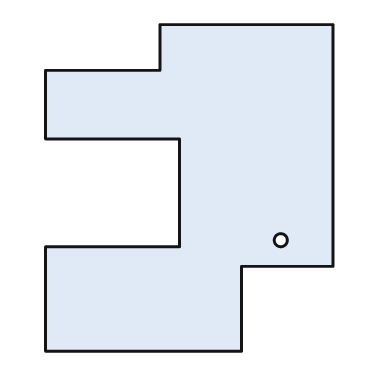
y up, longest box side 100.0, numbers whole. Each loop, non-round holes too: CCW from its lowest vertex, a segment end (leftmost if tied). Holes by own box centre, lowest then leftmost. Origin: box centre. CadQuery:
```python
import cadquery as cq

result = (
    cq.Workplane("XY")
    .moveTo(-44.0, -50.0)
    .lineTo(16.0, -50.0)
    .lineTo(16.0, -24.0)
    .lineTo(44.0, -24.0)
    .lineTo(44.0, 50.0)
    .lineTo(-9.0, 50.0)
    .lineTo(-9.0, 36.0)
    .lineTo(-44.0, 36.0)
    .lineTo(-44.0, 15.0)
    .lineTo(-3.0, 15.0)
    .lineTo(-3.0, -18.0)
    .lineTo(-44.0, -18.0)
    .close()
    .moveTo(28.0, -16.0)
    .circle(2.0)
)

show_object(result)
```